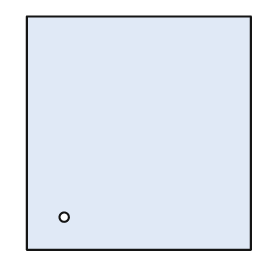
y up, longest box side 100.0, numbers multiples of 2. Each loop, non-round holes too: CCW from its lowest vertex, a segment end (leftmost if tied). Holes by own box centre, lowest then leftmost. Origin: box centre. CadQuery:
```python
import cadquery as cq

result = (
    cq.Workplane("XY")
    .moveTo(-48.0, -50.0)
    .lineTo(48.0, -50.0)
    .lineTo(48.0, 50.0)
    .lineTo(-48.0, 50.0)
    .close()
    .moveTo(-32.0, -36.0)
    .circle(2.0)
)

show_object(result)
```